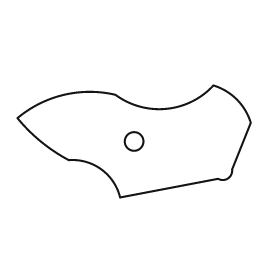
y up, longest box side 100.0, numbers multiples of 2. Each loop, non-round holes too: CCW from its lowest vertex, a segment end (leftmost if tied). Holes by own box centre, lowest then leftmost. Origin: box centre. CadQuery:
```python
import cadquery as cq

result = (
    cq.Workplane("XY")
    .moveTo(-6.0, -24.0)
    .lineTo(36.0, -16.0)
    .threePointArc((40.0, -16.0), (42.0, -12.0))
    .lineTo(50.0, 8.0)
    .threePointArc((44.0, 18.0), (34.0, 24.0))
    .threePointArc((14.0, 14.0), (-8.0, 20.0))
    .threePointArc((-30.0, 20.0), (-50.0, 10.0))
    .threePointArc((-40.0, 0.0), (-28.0, -8.0))
    .threePointArc((-14.0, -12.0), (-6.0, -24.0))
    .close()
    .moveTo(0.0, 0.0)
    .circle(4.0)
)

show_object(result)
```